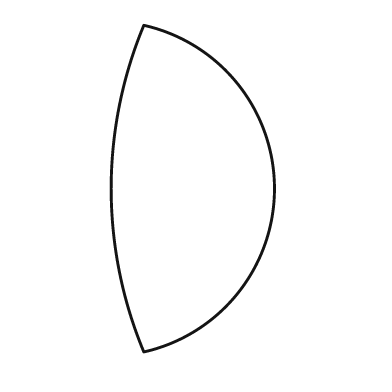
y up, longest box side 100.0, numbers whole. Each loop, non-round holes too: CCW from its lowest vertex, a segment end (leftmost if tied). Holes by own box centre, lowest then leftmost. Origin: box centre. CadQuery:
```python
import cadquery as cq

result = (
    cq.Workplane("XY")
    .moveTo(-15.0, -50.0)
    .threePointArc((25.0, 0.0), (-15.0, 50.0))
    .threePointArc((-25.0, 0.0), (-15.0, -50.0))
    .close()
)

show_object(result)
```